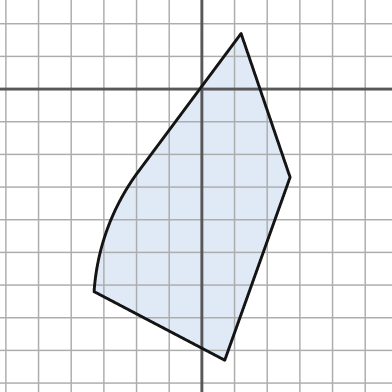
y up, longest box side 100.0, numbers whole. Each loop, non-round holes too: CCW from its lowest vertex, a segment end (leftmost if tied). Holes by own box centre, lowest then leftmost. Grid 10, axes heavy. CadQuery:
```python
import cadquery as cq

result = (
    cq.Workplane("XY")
    .moveTo(7.0, -83.0)
    .lineTo(27.0, -27.0)
    .lineTo(12.0, 17.0)
    .lineTo(-20.0, -26.0)
    .threePointArc((-29.0, -43.0), (-33.0, -62.0))
    .close()
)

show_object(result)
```